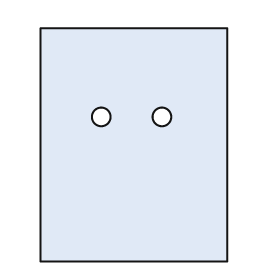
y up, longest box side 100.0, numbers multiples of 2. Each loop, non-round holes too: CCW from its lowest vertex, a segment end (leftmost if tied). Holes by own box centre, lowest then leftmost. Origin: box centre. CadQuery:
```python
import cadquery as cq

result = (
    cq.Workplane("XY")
    .moveTo(-40.0, -50.0)
    .lineTo(40.0, -50.0)
    .lineTo(40.0, 50.0)
    .lineTo(-40.0, 50.0)
    .close()
    .moveTo(-14.0, 12.0)
    .circle(4.0)
    .moveTo(12.0, 12.0)
    .circle(4.0)
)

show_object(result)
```